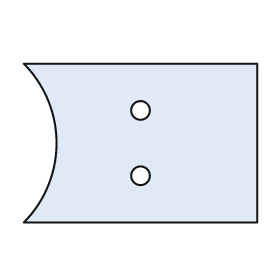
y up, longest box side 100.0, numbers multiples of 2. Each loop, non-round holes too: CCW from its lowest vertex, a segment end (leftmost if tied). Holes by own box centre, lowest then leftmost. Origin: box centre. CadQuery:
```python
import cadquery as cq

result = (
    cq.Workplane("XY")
    .moveTo(-50.0, -34.0)
    .lineTo(50.0, -34.0)
    .lineTo(50.0, 34.0)
    .lineTo(-50.0, 34.0)
    .threePointArc((-36.0, 0.0), (-50.0, -34.0))
    .close()
    .moveTo(0.0, -14.0)
    .circle(4.0)
    .moveTo(0.0, 14.0)
    .circle(4.0)
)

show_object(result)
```